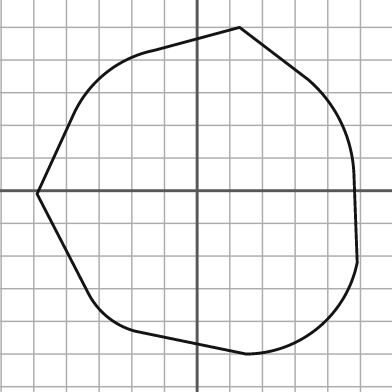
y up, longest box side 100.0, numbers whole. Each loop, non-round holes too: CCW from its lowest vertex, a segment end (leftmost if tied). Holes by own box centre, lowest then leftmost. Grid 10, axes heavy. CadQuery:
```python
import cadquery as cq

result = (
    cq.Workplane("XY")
    .moveTo(15.0, -50.0)
    .threePointArc((37.0, -42.0), (49.0, -22.0))
    .lineTo(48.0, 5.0)
    .threePointArc((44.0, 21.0), (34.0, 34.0))
    .lineTo(13.0, 50.0)
    .lineTo(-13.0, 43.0)
    .threePointArc((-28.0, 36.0), (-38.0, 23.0))
    .lineTo(-49.0, -1.0)
    .lineTo(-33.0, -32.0)
    .threePointArc((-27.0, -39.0), (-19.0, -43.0))
    .close()
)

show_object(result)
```